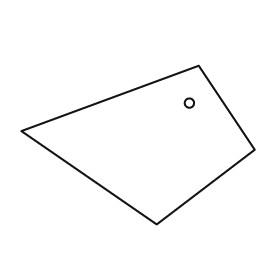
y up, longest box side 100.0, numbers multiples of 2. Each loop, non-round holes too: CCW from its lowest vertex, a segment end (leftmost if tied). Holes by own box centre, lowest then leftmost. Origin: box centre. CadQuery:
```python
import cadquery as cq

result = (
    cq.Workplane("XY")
    .moveTo(8.0, -34.0)
    .lineTo(50.0, -2.0)
    .lineTo(26.0, 34.0)
    .lineTo(-50.0, 6.0)
    .close()
    .moveTo(22.0, 18.0)
    .circle(2.0)
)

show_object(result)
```